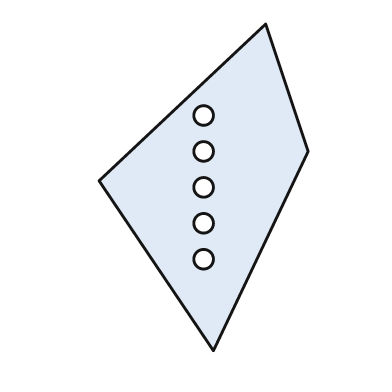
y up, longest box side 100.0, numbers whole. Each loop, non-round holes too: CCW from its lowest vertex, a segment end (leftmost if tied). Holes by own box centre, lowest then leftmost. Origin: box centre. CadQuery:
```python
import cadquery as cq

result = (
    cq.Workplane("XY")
    .moveTo(3.0, -50.0)
    .lineTo(32.0, 11.0)
    .lineTo(19.0, 50.0)
    .lineTo(-32.0, 2.0)
    .close()
    .moveTo(0.0, -22.0)
    .circle(3.0)
    .moveTo(0.0, -11.0)
    .circle(3.0)
    .moveTo(0.0, 0.0)
    .circle(3.0)
    .moveTo(0.0, 11.0)
    .circle(3.0)
    .moveTo(0.0, 22.0)
    .circle(3.0)
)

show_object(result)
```